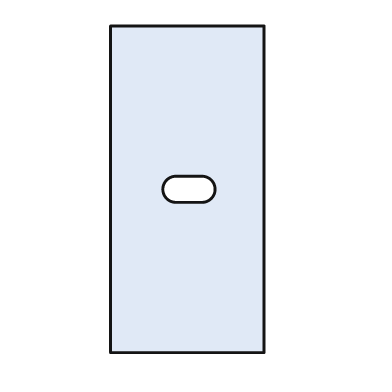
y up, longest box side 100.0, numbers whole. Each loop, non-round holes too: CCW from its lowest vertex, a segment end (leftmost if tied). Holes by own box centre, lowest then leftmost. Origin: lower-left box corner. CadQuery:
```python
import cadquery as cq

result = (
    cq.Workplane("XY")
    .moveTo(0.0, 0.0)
    .lineTo(47.0, 0.0)
    .lineTo(47.0, 100.0)
    .lineTo(0.0, 100.0)
    .close()
    .moveTo(20.0, 46.0)
    .lineTo(28.0, 46.0)
    .threePointArc((32.0, 50.0), (28.0, 54.0))
    .lineTo(20.0, 54.0)
    .threePointArc((16.0, 50.0), (20.0, 46.0))
    .close()
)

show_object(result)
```